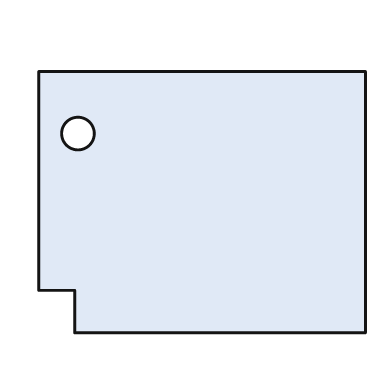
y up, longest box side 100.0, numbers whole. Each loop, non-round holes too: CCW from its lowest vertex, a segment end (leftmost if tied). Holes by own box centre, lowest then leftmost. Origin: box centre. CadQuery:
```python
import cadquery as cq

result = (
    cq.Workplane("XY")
    .moveTo(-39.0, -40.0)
    .lineTo(50.0, -40.0)
    .lineTo(50.0, 40.0)
    .lineTo(-50.0, 40.0)
    .lineTo(-50.0, -27.0)
    .lineTo(-39.0, -27.0)
    .close()
    .moveTo(-38.0, 21.0)
    .circle(5.0)
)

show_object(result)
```